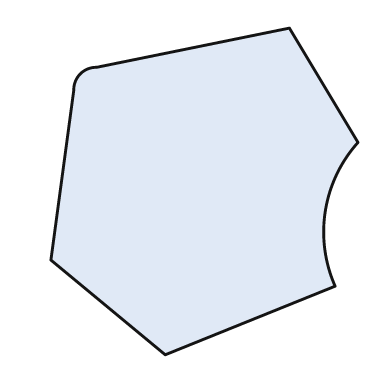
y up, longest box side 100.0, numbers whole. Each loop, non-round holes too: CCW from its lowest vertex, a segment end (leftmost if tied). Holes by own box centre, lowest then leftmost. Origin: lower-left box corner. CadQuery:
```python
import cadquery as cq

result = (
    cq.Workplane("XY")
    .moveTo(35.0, 0.0)
    .lineTo(87.0, 21.0)
    .threePointArc((84.0, 44.0), (94.0, 65.0))
    .lineTo(73.0, 100.0)
    .lineTo(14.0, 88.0)
    .threePointArc((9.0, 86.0), (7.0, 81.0))
    .lineTo(0.0, 29.0)
    .close()
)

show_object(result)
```